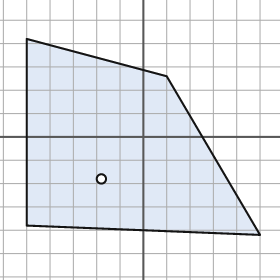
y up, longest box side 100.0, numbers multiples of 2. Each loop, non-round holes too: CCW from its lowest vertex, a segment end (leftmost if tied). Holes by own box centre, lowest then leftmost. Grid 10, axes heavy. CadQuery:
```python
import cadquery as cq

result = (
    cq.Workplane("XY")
    .moveTo(50.0, -42.0)
    .lineTo(10.0, 26.0)
    .lineTo(-50.0, 42.0)
    .lineTo(-50.0, -38.0)
    .close()
    .moveTo(-18.0, -18.0)
    .circle(2.0)
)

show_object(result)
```